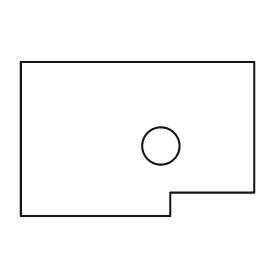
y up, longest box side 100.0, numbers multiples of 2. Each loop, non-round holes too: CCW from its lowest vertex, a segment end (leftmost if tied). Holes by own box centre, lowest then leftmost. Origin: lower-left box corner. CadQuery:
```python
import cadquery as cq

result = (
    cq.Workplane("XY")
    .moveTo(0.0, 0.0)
    .lineTo(64.0, 0.0)
    .lineTo(64.0, 10.0)
    .lineTo(100.0, 10.0)
    .lineTo(100.0, 66.0)
    .lineTo(0.0, 66.0)
    .close()
    .moveTo(60.0, 30.0)
    .circle(8.0)
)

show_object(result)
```